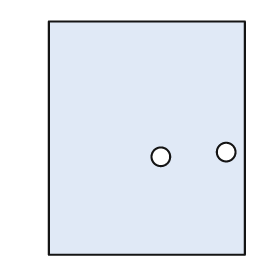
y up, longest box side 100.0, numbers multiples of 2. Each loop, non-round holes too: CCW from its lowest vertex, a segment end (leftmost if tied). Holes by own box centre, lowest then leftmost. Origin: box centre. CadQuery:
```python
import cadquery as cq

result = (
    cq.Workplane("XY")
    .moveTo(-42.0, -50.0)
    .lineTo(42.0, -50.0)
    .lineTo(42.0, 50.0)
    .lineTo(-42.0, 50.0)
    .close()
    .moveTo(6.0, -8.0)
    .circle(4.0)
    .moveTo(34.0, -6.0)
    .circle(4.0)
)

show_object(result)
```